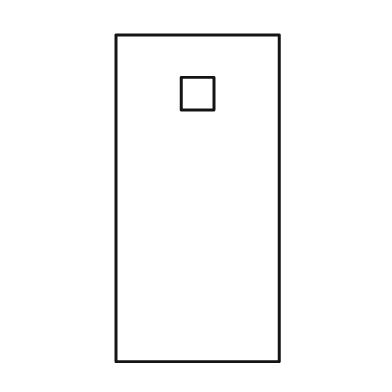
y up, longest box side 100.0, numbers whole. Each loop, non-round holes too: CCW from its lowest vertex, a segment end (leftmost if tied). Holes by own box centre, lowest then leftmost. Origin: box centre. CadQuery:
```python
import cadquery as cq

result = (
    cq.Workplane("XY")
    .moveTo(-25.0, -50.0)
    .lineTo(25.0, -50.0)
    .lineTo(25.0, 50.0)
    .lineTo(-25.0, 50.0)
    .close()
    .moveTo(-5.0, 27.0)
    .lineTo(5.0, 27.0)
    .lineTo(5.0, 37.0)
    .lineTo(-5.0, 37.0)
    .close()
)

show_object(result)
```